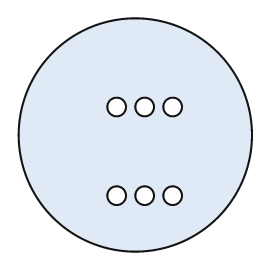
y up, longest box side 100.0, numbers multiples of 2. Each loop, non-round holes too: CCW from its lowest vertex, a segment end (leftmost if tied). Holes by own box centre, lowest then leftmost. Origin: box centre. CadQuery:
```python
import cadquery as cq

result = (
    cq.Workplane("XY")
    .moveTo(0.0, 0.0)
    .circle(50.0)
    .moveTo(-8.0, -26.0)
    .circle(4.0)
    .moveTo(4.0, -26.0)
    .circle(4.0)
    .moveTo(16.0, -26.0)
    .circle(4.0)
    .moveTo(-8.0, 12.0)
    .circle(4.0)
    .moveTo(4.0, 12.0)
    .circle(4.0)
    .moveTo(16.0, 12.0)
    .circle(4.0)
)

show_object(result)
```